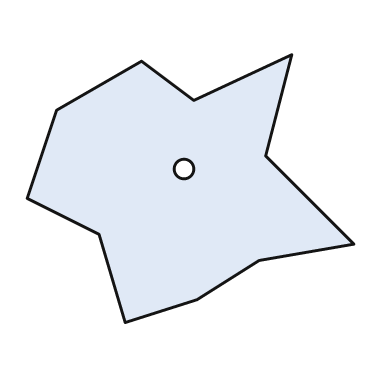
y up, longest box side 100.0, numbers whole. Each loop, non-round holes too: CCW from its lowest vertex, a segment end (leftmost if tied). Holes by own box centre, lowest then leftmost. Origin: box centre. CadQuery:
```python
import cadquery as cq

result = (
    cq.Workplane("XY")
    .moveTo(-20.0, -41.0)
    .lineTo(2.0, -34.0)
    .lineTo(21.0, -22.0)
    .lineTo(50.0, -17.0)
    .lineTo(23.0, 10.0)
    .lineTo(31.0, 41.0)
    .lineTo(1.0, 27.0)
    .lineTo(-15.0, 39.0)
    .lineTo(-41.0, 24.0)
    .lineTo(-50.0, -3.0)
    .lineTo(-28.0, -14.0)
    .close()
    .moveTo(-2.0, 6.0)
    .circle(3.0)
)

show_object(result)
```